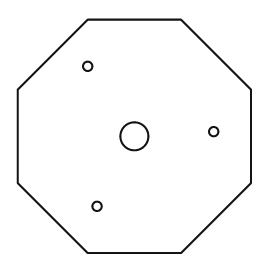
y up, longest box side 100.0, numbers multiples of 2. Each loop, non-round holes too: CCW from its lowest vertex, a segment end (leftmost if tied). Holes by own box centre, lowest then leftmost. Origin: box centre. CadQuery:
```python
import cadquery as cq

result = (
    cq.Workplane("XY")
    .moveTo(-20.0, -50.0)
    .lineTo(20.0, -50.0)
    .lineTo(50.0, -20.0)
    .lineTo(50.0, 20.0)
    .lineTo(20.0, 50.0)
    .lineTo(-20.0, 50.0)
    .lineTo(-50.0, 20.0)
    .lineTo(-50.0, -20.0)
    .close()
    .moveTo(-16.0, -30.0)
    .circle(2.0)
    .moveTo(0.0, 0.0)
    .circle(6.0)
    .moveTo(34.0, 2.0)
    .circle(2.0)
    .moveTo(-20.0, 30.0)
    .circle(2.0)
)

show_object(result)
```